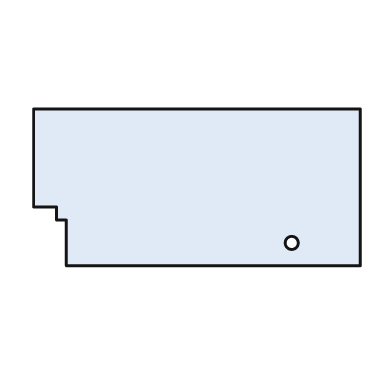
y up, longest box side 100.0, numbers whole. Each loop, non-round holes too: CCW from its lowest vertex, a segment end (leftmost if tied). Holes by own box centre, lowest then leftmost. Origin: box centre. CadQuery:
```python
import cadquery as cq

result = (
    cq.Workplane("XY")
    .moveTo(-40.0, -24.0)
    .lineTo(50.0, -24.0)
    .lineTo(50.0, 24.0)
    .lineTo(-50.0, 24.0)
    .lineTo(-50.0, -6.0)
    .lineTo(-43.0, -6.0)
    .lineTo(-43.0, -10.0)
    .lineTo(-40.0, -10.0)
    .close()
    .moveTo(29.0, -17.0)
    .circle(2.0)
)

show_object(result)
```